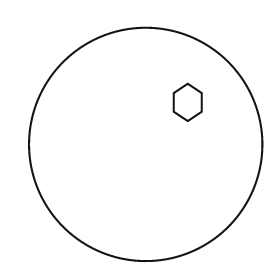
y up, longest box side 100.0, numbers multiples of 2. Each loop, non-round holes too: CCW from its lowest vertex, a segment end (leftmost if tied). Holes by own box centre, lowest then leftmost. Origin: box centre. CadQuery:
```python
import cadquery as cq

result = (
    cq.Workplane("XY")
    .moveTo(0.0, 0.0)
    .circle(50.0)
    .moveTo(18.0, 10.0)
    .lineTo(24.0, 14.0)
    .lineTo(24.0, 22.0)
    .lineTo(18.0, 26.0)
    .lineTo(12.0, 22.0)
    .lineTo(12.0, 14.0)
    .close()
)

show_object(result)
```